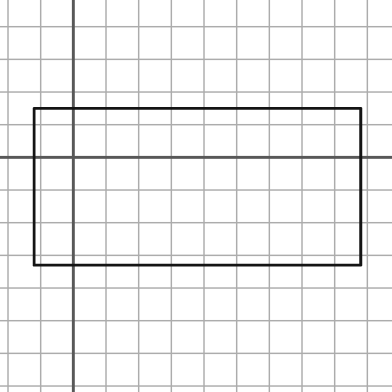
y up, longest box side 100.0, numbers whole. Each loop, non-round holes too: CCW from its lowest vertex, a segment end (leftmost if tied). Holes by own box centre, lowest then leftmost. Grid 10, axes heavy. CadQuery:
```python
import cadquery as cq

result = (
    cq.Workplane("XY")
    .moveTo(-12.0, -33.0)
    .lineTo(88.0, -33.0)
    .lineTo(88.0, 15.0)
    .lineTo(-12.0, 15.0)
    .close()
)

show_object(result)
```